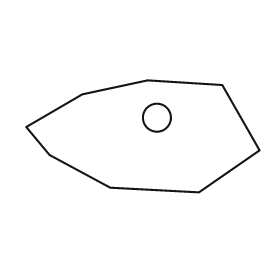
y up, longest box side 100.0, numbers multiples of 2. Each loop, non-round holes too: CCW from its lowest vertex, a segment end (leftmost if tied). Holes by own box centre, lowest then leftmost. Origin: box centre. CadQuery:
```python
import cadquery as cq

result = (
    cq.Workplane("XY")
    .moveTo(24.0, -24.0)
    .lineTo(50.0, -6.0)
    .lineTo(34.0, 22.0)
    .lineTo(2.0, 24.0)
    .lineTo(-26.0, 18.0)
    .lineTo(-50.0, 4.0)
    .lineTo(-40.0, -8.0)
    .lineTo(-14.0, -22.0)
    .close()
    .moveTo(6.0, 8.0)
    .circle(6.0)
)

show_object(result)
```